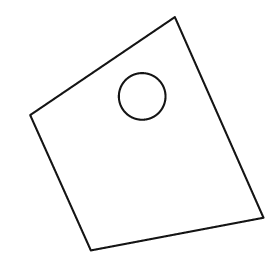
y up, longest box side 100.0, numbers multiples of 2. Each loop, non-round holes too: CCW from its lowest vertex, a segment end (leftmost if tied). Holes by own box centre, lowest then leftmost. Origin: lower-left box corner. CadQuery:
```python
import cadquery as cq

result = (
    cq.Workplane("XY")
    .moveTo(26.0, 0.0)
    .lineTo(100.0, 14.0)
    .lineTo(62.0, 100.0)
    .lineTo(0.0, 58.0)
    .close()
    .moveTo(48.0, 66.0)
    .circle(10.0)
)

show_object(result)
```